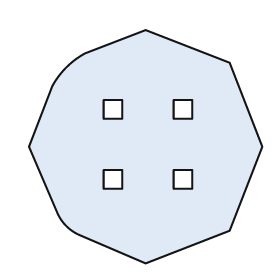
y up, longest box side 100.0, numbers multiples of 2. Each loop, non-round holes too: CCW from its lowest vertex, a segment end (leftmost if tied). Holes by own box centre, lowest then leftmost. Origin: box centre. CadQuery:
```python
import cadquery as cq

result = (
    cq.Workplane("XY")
    .moveTo(0.0, -50.0)
    .lineTo(36.0, -36.0)
    .lineTo(50.0, 0.0)
    .lineTo(36.0, 36.0)
    .lineTo(0.0, 50.0)
    .lineTo(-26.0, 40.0)
    .threePointArc((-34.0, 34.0), (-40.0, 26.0))
    .lineTo(-50.0, 0.0)
    .lineTo(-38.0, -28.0)
    .threePointArc((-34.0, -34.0), (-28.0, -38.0))
    .close()
    .moveTo(-18.0, -18.0)
    .lineTo(-10.0, -18.0)
    .lineTo(-10.0, -10.0)
    .lineTo(-18.0, -10.0)
    .close()
    .moveTo(12.0, -18.0)
    .lineTo(20.0, -18.0)
    .lineTo(20.0, -10.0)
    .lineTo(12.0, -10.0)
    .close()
    .moveTo(-18.0, 12.0)
    .lineTo(-10.0, 12.0)
    .lineTo(-10.0, 20.0)
    .lineTo(-18.0, 20.0)
    .close()
    .moveTo(12.0, 12.0)
    .lineTo(20.0, 12.0)
    .lineTo(20.0, 20.0)
    .lineTo(12.0, 20.0)
    .close()
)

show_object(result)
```